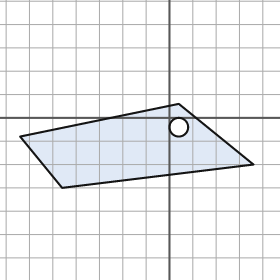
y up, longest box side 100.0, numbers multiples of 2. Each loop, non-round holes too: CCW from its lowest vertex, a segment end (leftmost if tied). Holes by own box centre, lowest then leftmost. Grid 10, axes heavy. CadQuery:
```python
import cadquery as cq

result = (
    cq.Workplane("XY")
    .moveTo(-46.0, -30.0)
    .lineTo(36.0, -20.0)
    .lineTo(4.0, 6.0)
    .lineTo(-64.0, -8.0)
    .close()
    .moveTo(4.0, -4.0)
    .circle(4.0)
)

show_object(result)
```